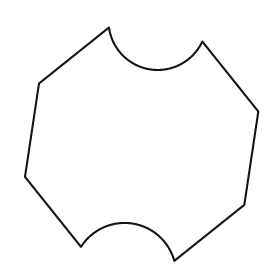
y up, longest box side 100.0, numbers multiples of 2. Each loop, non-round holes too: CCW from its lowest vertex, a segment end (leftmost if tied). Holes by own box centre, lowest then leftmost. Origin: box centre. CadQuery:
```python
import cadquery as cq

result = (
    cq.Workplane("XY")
    .moveTo(14.0, -50.0)
    .lineTo(44.0, -26.0)
    .lineTo(50.0, 14.0)
    .lineTo(26.0, 44.0)
    .threePointArc((4.0, 32.0), (-14.0, 50.0))
    .lineTo(-44.0, 26.0)
    .lineTo(-50.0, -14.0)
    .lineTo(-26.0, -44.0)
    .threePointArc((-4.0, -34.0), (14.0, -50.0))
    .close()
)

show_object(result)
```